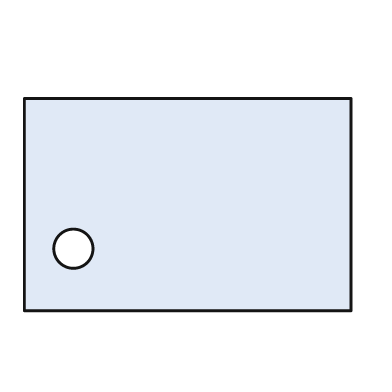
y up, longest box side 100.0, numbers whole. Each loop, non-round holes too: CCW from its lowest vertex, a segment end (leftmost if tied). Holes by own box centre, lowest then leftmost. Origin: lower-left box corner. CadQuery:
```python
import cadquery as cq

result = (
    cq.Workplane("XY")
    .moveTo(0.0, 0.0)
    .lineTo(100.0, 0.0)
    .lineTo(100.0, 65.0)
    .lineTo(0.0, 65.0)
    .close()
    .moveTo(15.0, 19.0)
    .circle(6.0)
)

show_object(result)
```